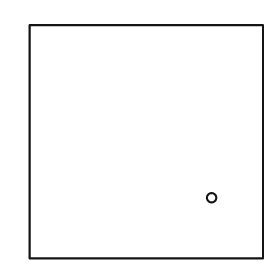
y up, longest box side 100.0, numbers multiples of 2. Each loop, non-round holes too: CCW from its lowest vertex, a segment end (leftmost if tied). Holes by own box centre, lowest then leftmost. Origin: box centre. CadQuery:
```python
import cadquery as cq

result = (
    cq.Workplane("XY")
    .moveTo(-50.0, -50.0)
    .lineTo(50.0, -50.0)
    .lineTo(50.0, 50.0)
    .lineTo(-50.0, 50.0)
    .close()
    .moveTo(28.0, -24.0)
    .circle(2.0)
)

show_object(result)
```